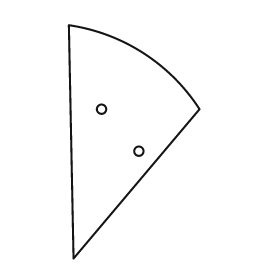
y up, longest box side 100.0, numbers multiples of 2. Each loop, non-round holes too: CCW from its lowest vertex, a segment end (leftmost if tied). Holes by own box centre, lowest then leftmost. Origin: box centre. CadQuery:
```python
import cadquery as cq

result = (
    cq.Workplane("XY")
    .moveTo(-26.0, -50.0)
    .lineTo(28.0, 14.0)
    .threePointArc((4.0, 38.0), (-28.0, 50.0))
    .close()
    .moveTo(2.0, -4.0)
    .circle(2.0)
    .moveTo(-14.0, 14.0)
    .circle(2.0)
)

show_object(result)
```